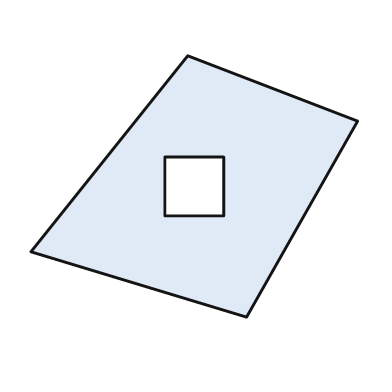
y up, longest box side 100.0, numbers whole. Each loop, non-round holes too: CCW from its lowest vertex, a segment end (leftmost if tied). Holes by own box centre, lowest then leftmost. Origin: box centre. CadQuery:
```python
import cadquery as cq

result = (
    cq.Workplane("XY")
    .moveTo(16.0, -40.0)
    .lineTo(50.0, 20.0)
    .lineTo(-2.0, 40.0)
    .lineTo(-50.0, -20.0)
    .close()
    .moveTo(-9.0, -9.0)
    .lineTo(9.0, -9.0)
    .lineTo(9.0, 9.0)
    .lineTo(-9.0, 9.0)
    .close()
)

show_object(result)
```